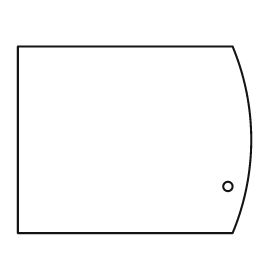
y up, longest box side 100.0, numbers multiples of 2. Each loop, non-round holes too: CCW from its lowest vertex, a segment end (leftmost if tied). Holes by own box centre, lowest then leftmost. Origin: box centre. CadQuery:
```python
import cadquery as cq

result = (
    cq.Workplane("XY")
    .moveTo(-50.0, -40.0)
    .lineTo(42.0, -40.0)
    .threePointArc((50.0, 0.0), (42.0, 40.0))
    .lineTo(-50.0, 40.0)
    .close()
    .moveTo(40.0, -20.0)
    .circle(2.0)
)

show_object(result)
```